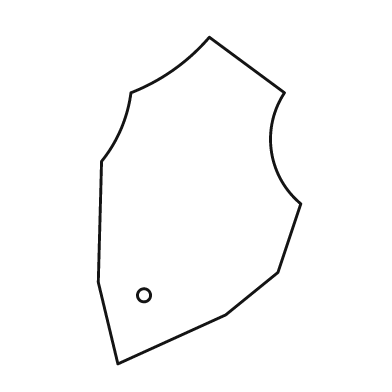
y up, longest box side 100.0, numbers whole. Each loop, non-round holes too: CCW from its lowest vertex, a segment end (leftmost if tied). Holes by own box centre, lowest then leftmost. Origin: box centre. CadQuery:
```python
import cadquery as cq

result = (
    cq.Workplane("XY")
    .moveTo(-25.0, -50.0)
    .lineTo(8.0, -35.0)
    .lineTo(24.0, -22.0)
    .lineTo(31.0, -1.0)
    .threePointArc((22.0, 15.0), (26.0, 33.0))
    .lineTo(3.0, 50.0)
    .threePointArc((-8.0, 40.0), (-21.0, 33.0))
    .threePointArc((-24.0, 22.0), (-30.0, 12.0))
    .lineTo(-31.0, -25.0)
    .close()
    .moveTo(-17.0, -29.0)
    .circle(2.0)
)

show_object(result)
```